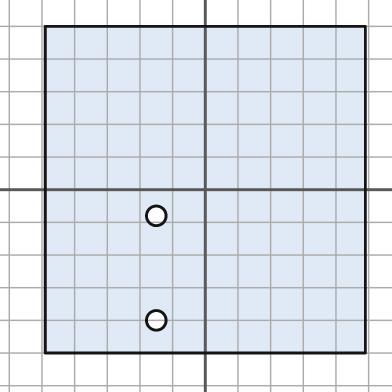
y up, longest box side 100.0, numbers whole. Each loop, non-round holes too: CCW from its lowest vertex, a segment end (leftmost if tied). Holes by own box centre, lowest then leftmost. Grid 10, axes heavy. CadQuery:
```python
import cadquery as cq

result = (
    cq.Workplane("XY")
    .moveTo(-49.0, -50.0)
    .lineTo(49.0, -50.0)
    .lineTo(49.0, 50.0)
    .lineTo(-49.0, 50.0)
    .close()
    .moveTo(-15.0, -40.0)
    .circle(3.0)
    .moveTo(-15.0, -8.0)
    .circle(3.0)
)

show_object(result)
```